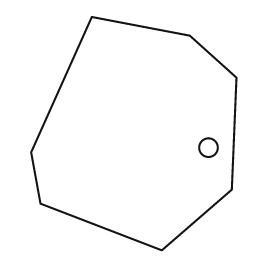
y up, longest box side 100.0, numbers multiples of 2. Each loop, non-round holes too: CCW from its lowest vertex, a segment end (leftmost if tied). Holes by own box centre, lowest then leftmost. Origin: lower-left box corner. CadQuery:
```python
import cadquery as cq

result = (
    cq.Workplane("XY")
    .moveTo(56.0, 0.0)
    .lineTo(86.0, 26.0)
    .lineTo(88.0, 74.0)
    .lineTo(68.0, 92.0)
    .lineTo(26.0, 100.0)
    .lineTo(0.0, 42.0)
    .lineTo(4.0, 20.0)
    .close()
    .moveTo(76.0, 44.0)
    .circle(4.0)
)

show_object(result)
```